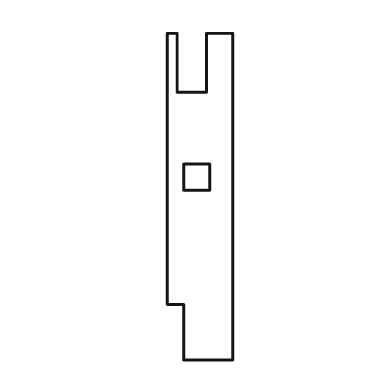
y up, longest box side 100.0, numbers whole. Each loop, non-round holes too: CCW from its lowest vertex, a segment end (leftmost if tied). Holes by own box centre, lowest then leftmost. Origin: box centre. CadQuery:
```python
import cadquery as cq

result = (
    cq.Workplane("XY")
    .moveTo(-5.0, -50.0)
    .lineTo(10.0, -50.0)
    .lineTo(10.0, 50.0)
    .lineTo(2.0, 50.0)
    .lineTo(2.0, 32.0)
    .lineTo(-7.0, 32.0)
    .lineTo(-7.0, 50.0)
    .lineTo(-10.0, 50.0)
    .lineTo(-10.0, -33.0)
    .lineTo(-5.0, -33.0)
    .close()
    .moveTo(-5.0, 2.0)
    .lineTo(3.0, 2.0)
    .lineTo(3.0, 10.0)
    .lineTo(-5.0, 10.0)
    .close()
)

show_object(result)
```